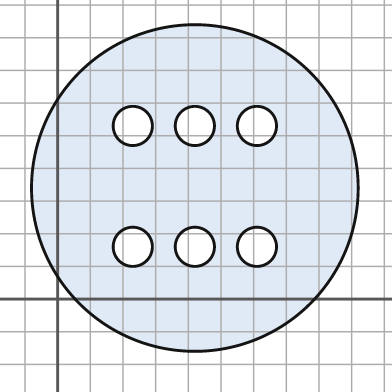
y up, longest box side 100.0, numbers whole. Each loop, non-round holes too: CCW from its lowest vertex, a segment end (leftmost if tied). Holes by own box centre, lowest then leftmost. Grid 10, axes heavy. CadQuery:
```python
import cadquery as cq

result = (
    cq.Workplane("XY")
    .moveTo(42.0, 34.0)
    .circle(50.0)
    .moveTo(23.0, 16.0)
    .circle(6.0)
    .moveTo(42.0, 16.0)
    .circle(6.0)
    .moveTo(61.0, 16.0)
    .circle(6.0)
    .moveTo(23.0, 53.0)
    .circle(6.0)
    .moveTo(42.0, 53.0)
    .circle(6.0)
    .moveTo(61.0, 53.0)
    .circle(6.0)
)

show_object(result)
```